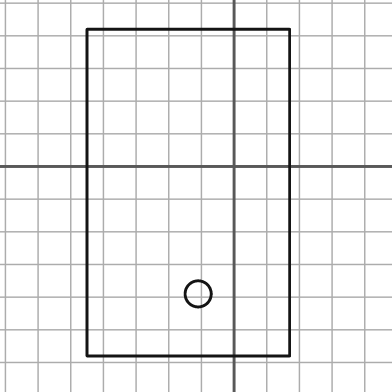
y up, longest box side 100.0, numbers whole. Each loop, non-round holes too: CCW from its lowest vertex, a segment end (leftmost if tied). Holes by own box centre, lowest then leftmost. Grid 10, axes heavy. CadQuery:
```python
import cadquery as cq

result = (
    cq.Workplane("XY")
    .moveTo(-45.0, -58.0)
    .lineTo(17.0, -58.0)
    .lineTo(17.0, 42.0)
    .lineTo(-45.0, 42.0)
    .close()
    .moveTo(-11.0, -39.0)
    .circle(4.0)
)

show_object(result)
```